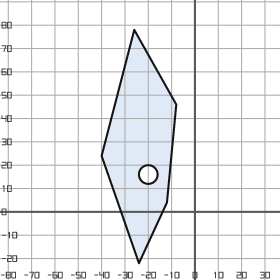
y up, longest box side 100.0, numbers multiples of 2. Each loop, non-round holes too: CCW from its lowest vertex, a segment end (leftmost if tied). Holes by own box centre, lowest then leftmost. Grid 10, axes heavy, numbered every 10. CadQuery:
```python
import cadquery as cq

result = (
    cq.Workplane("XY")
    .moveTo(-24.0, -22.0)
    .lineTo(-12.0, 4.0)
    .lineTo(-8.0, 46.0)
    .lineTo(-26.0, 78.0)
    .lineTo(-40.0, 24.0)
    .close()
    .moveTo(-20.0, 16.0)
    .circle(4.0)
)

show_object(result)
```